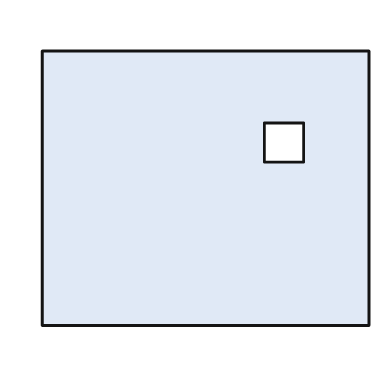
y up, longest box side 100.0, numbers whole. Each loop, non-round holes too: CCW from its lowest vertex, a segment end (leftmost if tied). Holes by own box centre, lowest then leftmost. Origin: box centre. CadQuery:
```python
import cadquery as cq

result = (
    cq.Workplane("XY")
    .moveTo(-50.0, -42.0)
    .lineTo(50.0, -42.0)
    .lineTo(50.0, 42.0)
    .lineTo(-50.0, 42.0)
    .close()
    .moveTo(18.0, 8.0)
    .lineTo(30.0, 8.0)
    .lineTo(30.0, 20.0)
    .lineTo(18.0, 20.0)
    .close()
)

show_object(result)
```